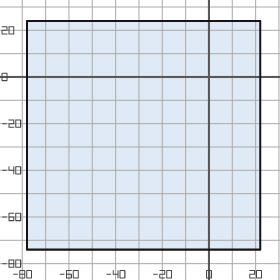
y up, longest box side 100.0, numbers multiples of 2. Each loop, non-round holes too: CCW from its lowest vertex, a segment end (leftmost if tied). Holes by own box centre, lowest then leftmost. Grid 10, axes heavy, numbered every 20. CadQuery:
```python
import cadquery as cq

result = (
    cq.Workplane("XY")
    .moveTo(-78.0, -74.0)
    .lineTo(22.0, -74.0)
    .lineTo(22.0, 24.0)
    .lineTo(-78.0, 24.0)
    .close()
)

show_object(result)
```